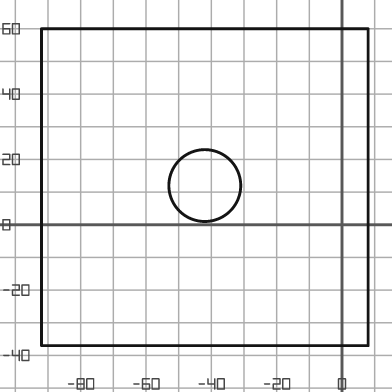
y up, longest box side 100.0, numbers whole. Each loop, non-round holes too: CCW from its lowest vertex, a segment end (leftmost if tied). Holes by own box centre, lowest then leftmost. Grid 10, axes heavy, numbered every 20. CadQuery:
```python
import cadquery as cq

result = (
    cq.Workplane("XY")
    .moveTo(-92.0, -37.0)
    .lineTo(8.0, -37.0)
    .lineTo(8.0, 60.0)
    .lineTo(-92.0, 60.0)
    .close()
    .moveTo(-42.0, 12.0)
    .circle(11.0)
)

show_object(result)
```